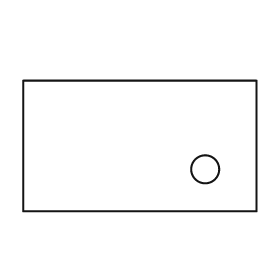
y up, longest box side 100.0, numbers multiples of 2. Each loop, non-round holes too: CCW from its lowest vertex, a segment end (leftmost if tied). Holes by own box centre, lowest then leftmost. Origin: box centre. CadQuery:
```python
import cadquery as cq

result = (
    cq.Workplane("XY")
    .moveTo(-50.0, -28.0)
    .lineTo(50.0, -28.0)
    .lineTo(50.0, 28.0)
    .lineTo(-50.0, 28.0)
    .close()
    .moveTo(28.0, -10.0)
    .circle(6.0)
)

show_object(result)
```